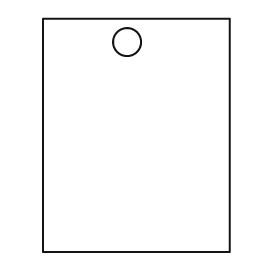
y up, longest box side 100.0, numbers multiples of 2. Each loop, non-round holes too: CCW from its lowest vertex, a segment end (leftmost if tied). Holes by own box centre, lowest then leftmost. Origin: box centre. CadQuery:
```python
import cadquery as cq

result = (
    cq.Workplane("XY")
    .moveTo(-40.0, -50.0)
    .lineTo(40.0, -50.0)
    .lineTo(40.0, 50.0)
    .lineTo(-40.0, 50.0)
    .close()
    .moveTo(-4.0, 40.0)
    .circle(6.0)
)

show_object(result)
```